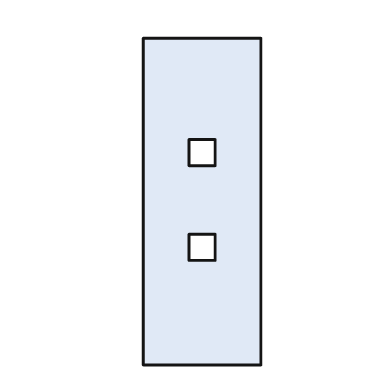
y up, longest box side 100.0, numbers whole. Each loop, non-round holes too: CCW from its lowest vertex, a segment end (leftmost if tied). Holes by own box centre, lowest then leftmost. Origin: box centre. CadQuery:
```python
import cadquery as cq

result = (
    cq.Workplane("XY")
    .moveTo(-18.0, -50.0)
    .lineTo(18.0, -50.0)
    .lineTo(18.0, 50.0)
    .lineTo(-18.0, 50.0)
    .close()
    .moveTo(-4.0, -18.0)
    .lineTo(4.0, -18.0)
    .lineTo(4.0, -10.0)
    .lineTo(-4.0, -10.0)
    .close()
    .moveTo(-4.0, 11.0)
    .lineTo(4.0, 11.0)
    .lineTo(4.0, 19.0)
    .lineTo(-4.0, 19.0)
    .close()
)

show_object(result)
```